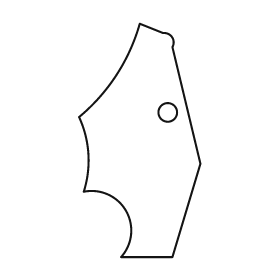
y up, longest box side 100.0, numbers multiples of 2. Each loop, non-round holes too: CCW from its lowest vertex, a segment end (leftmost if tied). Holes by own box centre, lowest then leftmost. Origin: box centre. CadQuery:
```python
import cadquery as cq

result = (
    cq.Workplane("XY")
    .moveTo(-8.0, -50.0)
    .lineTo(14.0, -50.0)
    .lineTo(26.0, -10.0)
    .lineTo(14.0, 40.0)
    .threePointArc((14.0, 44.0), (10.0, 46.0))
    .lineTo(0.0, 50.0)
    .threePointArc((-10.0, 28.0), (-26.0, 10.0))
    .threePointArc((-22.0, -6.0), (-24.0, -22.0))
    .threePointArc((-6.0, -30.0), (-8.0, -50.0))
    .close()
    .moveTo(12.0, 12.0)
    .circle(4.0)
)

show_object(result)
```